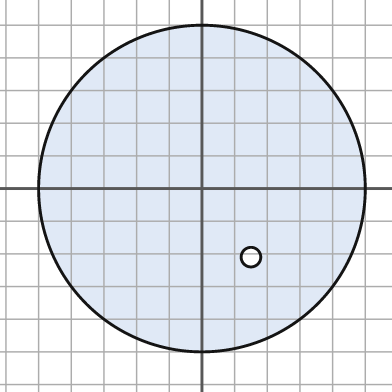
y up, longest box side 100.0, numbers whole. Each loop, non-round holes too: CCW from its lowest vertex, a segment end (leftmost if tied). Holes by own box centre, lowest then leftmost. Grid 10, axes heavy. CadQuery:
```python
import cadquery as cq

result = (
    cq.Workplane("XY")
    .moveTo(0.0, 0.0)
    .circle(50.0)
    .moveTo(15.0, -21.0)
    .circle(3.0)
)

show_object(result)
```